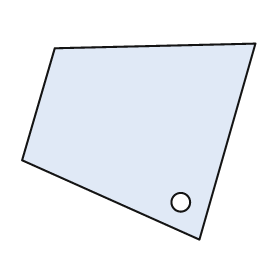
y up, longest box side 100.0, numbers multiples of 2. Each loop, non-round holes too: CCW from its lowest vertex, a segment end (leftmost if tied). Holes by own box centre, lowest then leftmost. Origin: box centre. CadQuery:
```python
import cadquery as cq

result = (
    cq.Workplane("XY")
    .moveTo(26.0, -42.0)
    .lineTo(50.0, 42.0)
    .lineTo(-36.0, 40.0)
    .lineTo(-50.0, -8.0)
    .close()
    .moveTo(18.0, -26.0)
    .circle(4.0)
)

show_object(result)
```